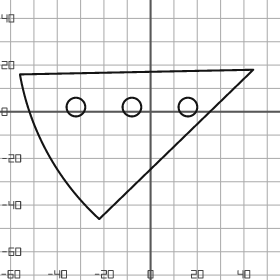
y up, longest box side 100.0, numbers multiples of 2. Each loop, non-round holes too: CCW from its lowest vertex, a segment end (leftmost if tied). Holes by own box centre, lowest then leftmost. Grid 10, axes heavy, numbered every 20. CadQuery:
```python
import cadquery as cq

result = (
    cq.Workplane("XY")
    .moveTo(-22.0, -46.0)
    .lineTo(44.0, 18.0)
    .lineTo(-56.0, 16.0)
    .threePointArc((-44.0, -18.0), (-22.0, -46.0))
    .close()
    .moveTo(-32.0, 2.0)
    .circle(4.0)
    .moveTo(-8.0, 2.0)
    .circle(4.0)
    .moveTo(16.0, 2.0)
    .circle(4.0)
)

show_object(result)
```